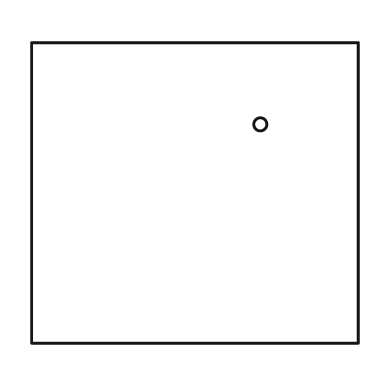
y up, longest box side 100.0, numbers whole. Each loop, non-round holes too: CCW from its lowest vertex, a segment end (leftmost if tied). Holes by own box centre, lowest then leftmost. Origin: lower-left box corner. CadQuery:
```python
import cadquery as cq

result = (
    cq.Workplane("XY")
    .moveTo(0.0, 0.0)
    .lineTo(100.0, 0.0)
    .lineTo(100.0, 92.0)
    .lineTo(0.0, 92.0)
    .close()
    .moveTo(70.0, 67.0)
    .circle(2.0)
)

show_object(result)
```